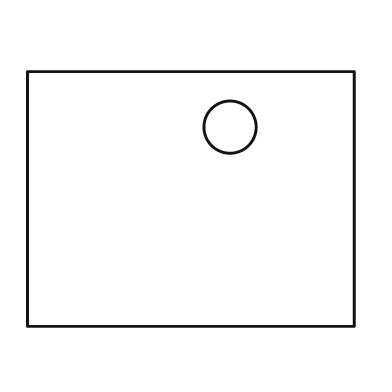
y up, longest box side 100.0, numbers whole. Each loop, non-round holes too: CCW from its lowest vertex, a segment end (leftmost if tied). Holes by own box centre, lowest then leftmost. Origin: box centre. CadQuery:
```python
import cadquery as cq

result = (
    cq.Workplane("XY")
    .moveTo(-50.0, -39.0)
    .lineTo(50.0, -39.0)
    .lineTo(50.0, 39.0)
    .lineTo(-50.0, 39.0)
    .close()
    .moveTo(12.0, 22.0)
    .circle(8.0)
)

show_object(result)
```